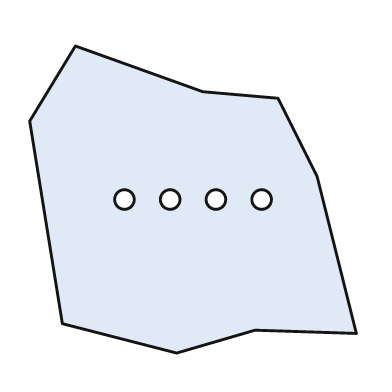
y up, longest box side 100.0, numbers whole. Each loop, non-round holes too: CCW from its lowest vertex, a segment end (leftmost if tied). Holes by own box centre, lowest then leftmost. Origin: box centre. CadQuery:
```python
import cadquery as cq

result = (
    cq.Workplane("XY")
    .moveTo(-5.0, -47.0)
    .lineTo(19.0, -40.0)
    .lineTo(50.0, -41.0)
    .lineTo(38.0, 7.0)
    .lineTo(26.0, 31.0)
    .lineTo(3.0, 33.0)
    .lineTo(-36.0, 47.0)
    .lineTo(-50.0, 24.0)
    .lineTo(-40.0, -38.0)
    .close()
    .moveTo(-21.0, 0.0)
    .circle(3.0)
    .moveTo(-7.0, 0.0)
    .circle(3.0)
    .moveTo(7.0, 0.0)
    .circle(3.0)
    .moveTo(21.0, 0.0)
    .circle(3.0)
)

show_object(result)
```